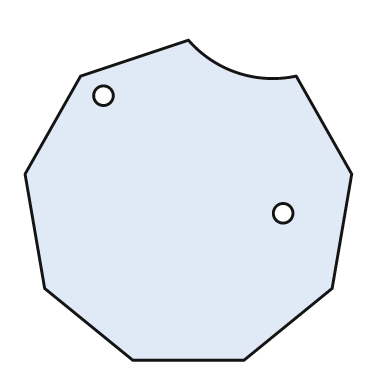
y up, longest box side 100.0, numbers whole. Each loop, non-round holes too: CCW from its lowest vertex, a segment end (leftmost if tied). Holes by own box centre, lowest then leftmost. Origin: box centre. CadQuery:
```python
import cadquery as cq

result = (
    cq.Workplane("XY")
    .moveTo(-17.0, -49.0)
    .lineTo(17.0, -49.0)
    .lineTo(44.0, -27.0)
    .lineTo(50.0, 8.0)
    .lineTo(33.0, 38.0)
    .threePointArc((15.0, 39.0), (0.0, 49.0))
    .lineTo(-33.0, 38.0)
    .lineTo(-50.0, 8.0)
    .lineTo(-44.0, -27.0)
    .close()
    .moveTo(29.0, -4.0)
    .circle(3.0)
    .moveTo(-26.0, 32.0)
    .circle(3.0)
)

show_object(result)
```